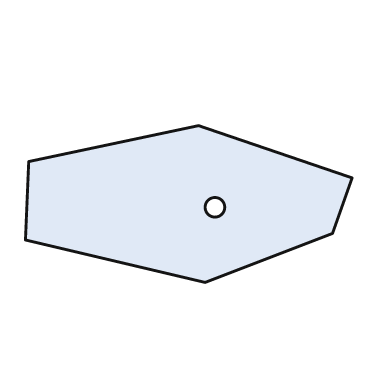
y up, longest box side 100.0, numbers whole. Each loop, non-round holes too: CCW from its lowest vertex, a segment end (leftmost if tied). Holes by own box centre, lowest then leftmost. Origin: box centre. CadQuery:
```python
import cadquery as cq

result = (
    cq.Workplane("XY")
    .moveTo(5.0, -24.0)
    .lineTo(44.0, -9.0)
    .lineTo(50.0, 8.0)
    .lineTo(3.0, 24.0)
    .lineTo(-49.0, 13.0)
    .lineTo(-50.0, -11.0)
    .close()
    .moveTo(8.0, -1.0)
    .circle(3.0)
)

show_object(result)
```